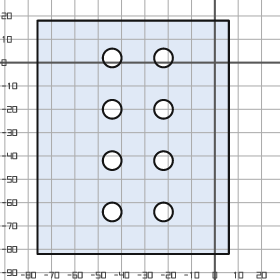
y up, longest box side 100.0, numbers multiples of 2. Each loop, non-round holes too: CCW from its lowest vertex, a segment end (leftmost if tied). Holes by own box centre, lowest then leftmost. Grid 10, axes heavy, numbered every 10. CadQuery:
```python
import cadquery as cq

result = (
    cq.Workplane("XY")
    .moveTo(-76.0, -82.0)
    .lineTo(6.0, -82.0)
    .lineTo(6.0, 18.0)
    .lineTo(-76.0, 18.0)
    .close()
    .moveTo(-44.0, -64.0)
    .circle(4.0)
    .moveTo(-22.0, -64.0)
    .circle(4.0)
    .moveTo(-44.0, -42.0)
    .circle(4.0)
    .moveTo(-22.0, -42.0)
    .circle(4.0)
    .moveTo(-44.0, -20.0)
    .circle(4.0)
    .moveTo(-22.0, -20.0)
    .circle(4.0)
    .moveTo(-44.0, 2.0)
    .circle(4.0)
    .moveTo(-22.0, 2.0)
    .circle(4.0)
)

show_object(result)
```